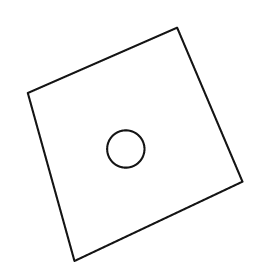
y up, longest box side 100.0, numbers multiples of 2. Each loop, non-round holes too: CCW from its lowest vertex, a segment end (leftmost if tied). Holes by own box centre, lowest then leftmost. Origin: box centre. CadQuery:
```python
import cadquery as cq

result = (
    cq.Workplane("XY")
    .moveTo(-26.0, -50.0)
    .lineTo(46.0, -16.0)
    .lineTo(18.0, 50.0)
    .lineTo(-46.0, 22.0)
    .close()
    .moveTo(-4.0, -2.0)
    .circle(8.0)
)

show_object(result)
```